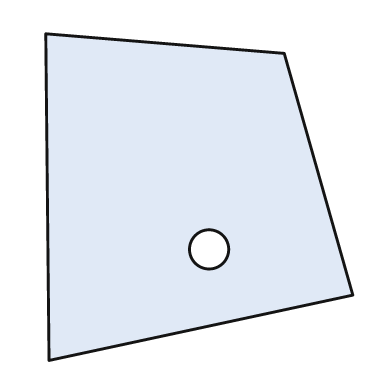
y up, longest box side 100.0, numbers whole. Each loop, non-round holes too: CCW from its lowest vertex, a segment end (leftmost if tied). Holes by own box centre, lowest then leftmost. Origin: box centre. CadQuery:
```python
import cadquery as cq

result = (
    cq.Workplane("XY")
    .moveTo(-46.0, -50.0)
    .lineTo(47.0, -30.0)
    .lineTo(26.0, 44.0)
    .lineTo(-47.0, 50.0)
    .close()
    .moveTo(3.0, -16.0)
    .circle(6.0)
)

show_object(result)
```